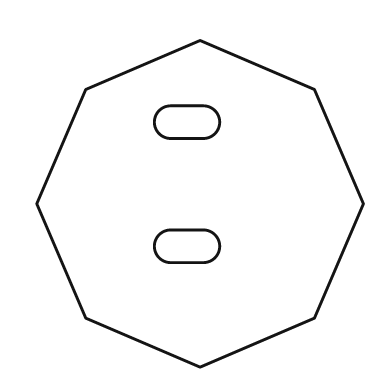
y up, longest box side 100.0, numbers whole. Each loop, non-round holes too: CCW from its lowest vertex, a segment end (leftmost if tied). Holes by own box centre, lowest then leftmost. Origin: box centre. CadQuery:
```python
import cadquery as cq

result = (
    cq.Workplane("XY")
    .moveTo(0.0, -50.0)
    .lineTo(35.0, -35.0)
    .lineTo(50.0, 0.0)
    .lineTo(35.0, 35.0)
    .lineTo(0.0, 50.0)
    .lineTo(-35.0, 35.0)
    .lineTo(-50.0, 0.0)
    .lineTo(-35.0, -35.0)
    .close()
    .moveTo(-9.0, -18.0)
    .lineTo(1.0, -18.0)
    .threePointArc((6.0, -13.0), (1.0, -8.0))
    .lineTo(-9.0, -8.0)
    .threePointArc((-14.0, -13.0), (-9.0, -18.0))
    .close()
    .moveTo(-9.0, 20.0)
    .lineTo(1.0, 20.0)
    .threePointArc((6.0, 25.0), (1.0, 30.0))
    .lineTo(-9.0, 30.0)
    .threePointArc((-14.0, 25.0), (-9.0, 20.0))
    .close()
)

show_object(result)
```